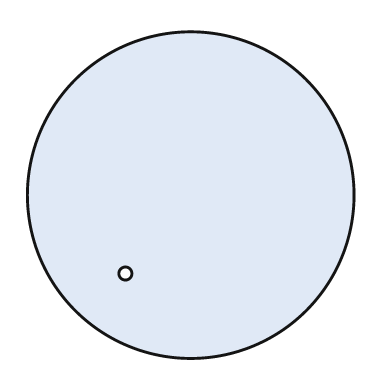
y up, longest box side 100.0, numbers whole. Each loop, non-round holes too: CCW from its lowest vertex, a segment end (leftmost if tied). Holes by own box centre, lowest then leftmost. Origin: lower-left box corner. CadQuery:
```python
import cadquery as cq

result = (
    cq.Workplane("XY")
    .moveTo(50.0, 50.0)
    .circle(50.0)
    .moveTo(30.0, 26.0)
    .circle(2.0)
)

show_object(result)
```